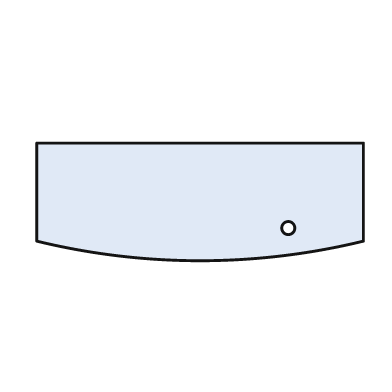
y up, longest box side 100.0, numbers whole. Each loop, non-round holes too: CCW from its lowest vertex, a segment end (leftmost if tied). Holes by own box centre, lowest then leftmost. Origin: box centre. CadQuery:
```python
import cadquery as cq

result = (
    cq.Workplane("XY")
    .moveTo(-50.0, -12.0)
    .threePointArc((0.0, -18.0), (50.0, -12.0))
    .lineTo(50.0, 18.0)
    .lineTo(-50.0, 18.0)
    .close()
    .moveTo(27.0, -8.0)
    .circle(2.0)
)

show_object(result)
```